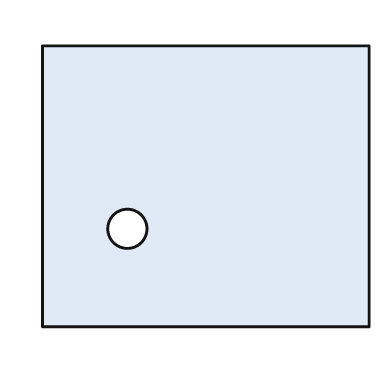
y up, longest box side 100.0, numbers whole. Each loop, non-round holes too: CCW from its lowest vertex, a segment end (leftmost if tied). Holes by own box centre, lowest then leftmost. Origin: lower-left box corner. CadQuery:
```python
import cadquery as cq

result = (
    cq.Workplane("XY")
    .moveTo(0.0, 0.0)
    .lineTo(100.0, 0.0)
    .lineTo(100.0, 86.0)
    .lineTo(0.0, 86.0)
    .close()
    .moveTo(26.0, 30.0)
    .circle(6.0)
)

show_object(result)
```